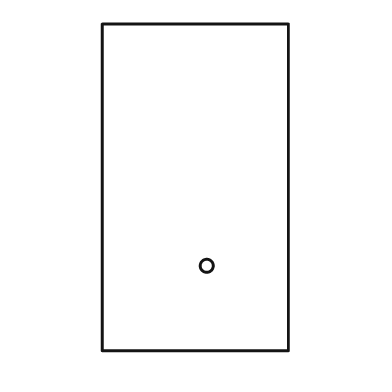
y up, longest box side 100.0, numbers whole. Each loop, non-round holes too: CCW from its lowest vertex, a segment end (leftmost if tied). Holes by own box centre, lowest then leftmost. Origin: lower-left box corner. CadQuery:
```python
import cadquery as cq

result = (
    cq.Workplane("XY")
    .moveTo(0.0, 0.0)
    .lineTo(57.0, 0.0)
    .lineTo(57.0, 100.0)
    .lineTo(0.0, 100.0)
    .close()
    .moveTo(32.0, 26.0)
    .circle(2.0)
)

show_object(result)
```